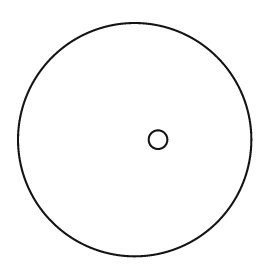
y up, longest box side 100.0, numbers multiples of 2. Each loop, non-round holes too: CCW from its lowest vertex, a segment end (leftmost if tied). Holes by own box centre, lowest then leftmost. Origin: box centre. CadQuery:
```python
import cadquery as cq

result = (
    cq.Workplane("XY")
    .moveTo(0.0, 0.0)
    .circle(50.0)
    .moveTo(10.0, 0.0)
    .circle(4.0)
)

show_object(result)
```